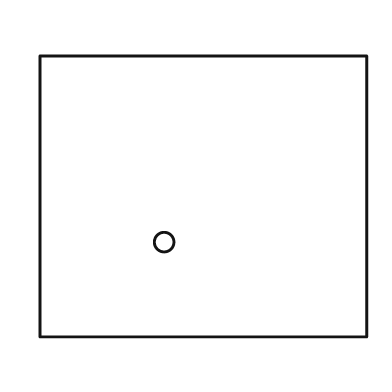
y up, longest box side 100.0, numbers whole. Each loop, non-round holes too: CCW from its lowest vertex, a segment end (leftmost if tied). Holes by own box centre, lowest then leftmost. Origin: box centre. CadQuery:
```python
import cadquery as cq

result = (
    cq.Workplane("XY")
    .moveTo(-50.0, -43.0)
    .lineTo(50.0, -43.0)
    .lineTo(50.0, 43.0)
    .lineTo(-50.0, 43.0)
    .close()
    .moveTo(-12.0, -14.0)
    .circle(3.0)
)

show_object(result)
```